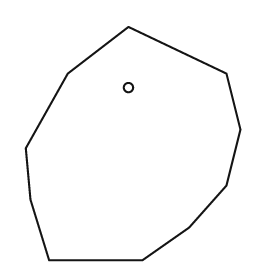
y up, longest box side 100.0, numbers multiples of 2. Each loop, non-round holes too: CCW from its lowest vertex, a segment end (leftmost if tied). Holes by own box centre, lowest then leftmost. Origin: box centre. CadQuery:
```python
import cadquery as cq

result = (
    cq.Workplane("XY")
    .moveTo(-36.0, -50.0)
    .lineTo(4.0, -50.0)
    .lineTo(24.0, -36.0)
    .lineTo(40.0, -18.0)
    .lineTo(46.0, 6.0)
    .lineTo(40.0, 30.0)
    .lineTo(-2.0, 50.0)
    .lineTo(-28.0, 30.0)
    .lineTo(-46.0, -2.0)
    .lineTo(-44.0, -24.0)
    .close()
    .moveTo(-2.0, 24.0)
    .circle(2.0)
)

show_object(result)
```